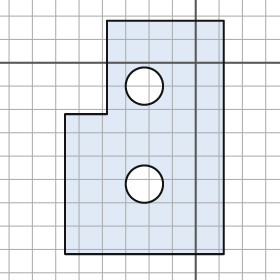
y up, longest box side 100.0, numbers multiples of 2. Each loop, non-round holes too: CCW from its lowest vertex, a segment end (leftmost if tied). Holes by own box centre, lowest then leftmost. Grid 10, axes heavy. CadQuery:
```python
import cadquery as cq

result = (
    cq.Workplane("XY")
    .moveTo(-56.0, -82.0)
    .lineTo(12.0, -82.0)
    .lineTo(12.0, 18.0)
    .lineTo(-38.0, 18.0)
    .lineTo(-38.0, -22.0)
    .lineTo(-56.0, -22.0)
    .close()
    .moveTo(-22.0, -52.0)
    .circle(8.0)
    .moveTo(-22.0, -10.0)
    .circle(8.0)
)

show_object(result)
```